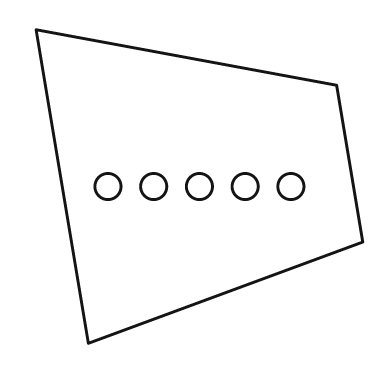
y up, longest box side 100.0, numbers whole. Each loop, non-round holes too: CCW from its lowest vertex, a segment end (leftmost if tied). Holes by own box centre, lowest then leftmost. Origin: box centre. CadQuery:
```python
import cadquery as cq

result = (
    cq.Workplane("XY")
    .moveTo(-34.0, -48.0)
    .lineTo(50.0, -17.0)
    .lineTo(42.0, 31.0)
    .lineTo(-50.0, 48.0)
    .close()
    .moveTo(-28.0, 0.0)
    .circle(4.0)
    .moveTo(-14.0, 0.0)
    .circle(4.0)
    .moveTo(0.0, 0.0)
    .circle(4.0)
    .moveTo(14.0, 0.0)
    .circle(4.0)
    .moveTo(28.0, 0.0)
    .circle(4.0)
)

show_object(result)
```